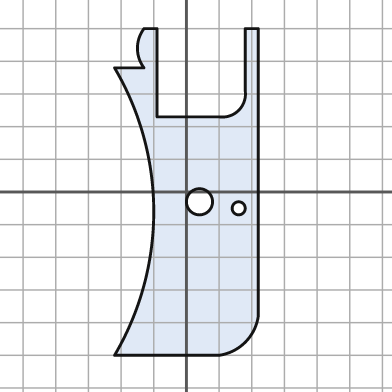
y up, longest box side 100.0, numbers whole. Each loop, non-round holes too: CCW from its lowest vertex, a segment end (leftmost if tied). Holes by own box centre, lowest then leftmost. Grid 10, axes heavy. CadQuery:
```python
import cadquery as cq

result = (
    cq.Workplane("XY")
    .moveTo(-22.0, -50.0)
    .lineTo(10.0, -50.0)
    .threePointArc((18.0, -46.0), (22.0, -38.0))
    .lineTo(22.0, 50.0)
    .lineTo(18.0, 50.0)
    .lineTo(18.0, 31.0)
    .threePointArc((16.0, 25.0), (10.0, 23.0))
    .lineTo(-9.0, 23.0)
    .lineTo(-9.0, 50.0)
    .lineTo(-13.0, 50.0)
    .threePointArc((-15.0, 44.0), (-13.0, 38.0))
    .lineTo(-22.0, 38.0)
    .threePointArc((-10.0, -6.0), (-22.0, -50.0))
    .close()
    .moveTo(16.0, -5.0)
    .circle(2.0)
    .moveTo(4.0, -3.0)
    .circle(4.0)
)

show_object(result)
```